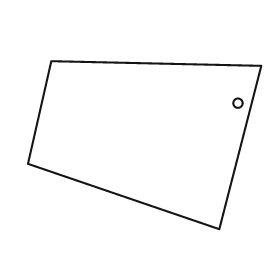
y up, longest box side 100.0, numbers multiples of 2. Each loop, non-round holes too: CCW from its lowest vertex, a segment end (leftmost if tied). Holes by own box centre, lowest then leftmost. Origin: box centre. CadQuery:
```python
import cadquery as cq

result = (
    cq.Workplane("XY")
    .moveTo(32.0, -36.0)
    .lineTo(50.0, 34.0)
    .lineTo(-40.0, 36.0)
    .lineTo(-50.0, -8.0)
    .close()
    .moveTo(40.0, 18.0)
    .circle(2.0)
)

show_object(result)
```